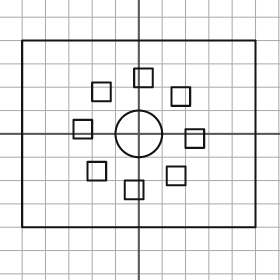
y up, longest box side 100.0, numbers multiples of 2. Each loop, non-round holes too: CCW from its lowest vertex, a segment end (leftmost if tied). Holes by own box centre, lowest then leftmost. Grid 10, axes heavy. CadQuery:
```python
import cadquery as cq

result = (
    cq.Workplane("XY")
    .moveTo(-50.0, -40.0)
    .lineTo(50.0, -40.0)
    .lineTo(50.0, 40.0)
    .lineTo(-50.0, 40.0)
    .close()
    .moveTo(-6.0, -28.0)
    .lineTo(2.0, -28.0)
    .lineTo(2.0, -20.0)
    .lineTo(-6.0, -20.0)
    .close()
    .moveTo(12.0, -22.0)
    .lineTo(20.0, -22.0)
    .lineTo(20.0, -14.0)
    .lineTo(12.0, -14.0)
    .close()
    .moveTo(-22.0, -20.0)
    .lineTo(-14.0, -20.0)
    .lineTo(-14.0, -12.0)
    .lineTo(-22.0, -12.0)
    .close()
    .moveTo(20.0, -6.0)
    .lineTo(28.0, -6.0)
    .lineTo(28.0, 2.0)
    .lineTo(20.0, 2.0)
    .close()
    .moveTo(0.0, 0.0)
    .circle(10.0)
    .moveTo(-28.0, -2.0)
    .lineTo(-20.0, -2.0)
    .lineTo(-20.0, 6.0)
    .lineTo(-28.0, 6.0)
    .close()
    .moveTo(14.0, 12.0)
    .lineTo(22.0, 12.0)
    .lineTo(22.0, 20.0)
    .lineTo(14.0, 20.0)
    .close()
    .moveTo(-20.0, 14.0)
    .lineTo(-12.0, 14.0)
    .lineTo(-12.0, 22.0)
    .lineTo(-20.0, 22.0)
    .close()
    .moveTo(-2.0, 20.0)
    .lineTo(6.0, 20.0)
    .lineTo(6.0, 28.0)
    .lineTo(-2.0, 28.0)
    .close()
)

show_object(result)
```